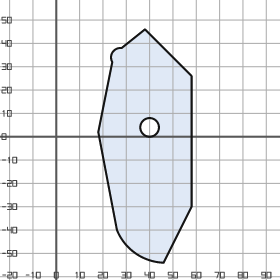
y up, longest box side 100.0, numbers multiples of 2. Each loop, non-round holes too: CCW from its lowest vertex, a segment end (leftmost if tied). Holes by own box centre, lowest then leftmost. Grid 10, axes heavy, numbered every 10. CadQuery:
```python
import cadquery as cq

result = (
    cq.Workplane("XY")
    .moveTo(46.0, -54.0)
    .lineTo(58.0, -30.0)
    .lineTo(58.0, 26.0)
    .lineTo(38.0, 46.0)
    .lineTo(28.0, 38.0)
    .threePointArc((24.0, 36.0), (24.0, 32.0))
    .lineTo(18.0, 2.0)
    .lineTo(26.0, -40.0)
    .threePointArc((34.0, -50.0), (46.0, -54.0))
    .close()
    .moveTo(40.0, 4.0)
    .circle(4.0)
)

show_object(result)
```